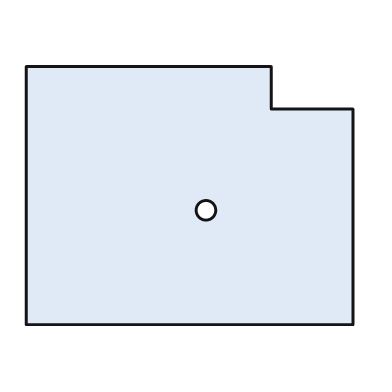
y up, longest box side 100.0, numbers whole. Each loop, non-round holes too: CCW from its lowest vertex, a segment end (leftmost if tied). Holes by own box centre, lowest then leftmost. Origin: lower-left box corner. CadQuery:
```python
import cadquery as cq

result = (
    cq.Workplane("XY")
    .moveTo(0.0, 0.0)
    .lineTo(100.0, 0.0)
    .lineTo(100.0, 66.0)
    .lineTo(75.0, 66.0)
    .lineTo(75.0, 79.0)
    .lineTo(0.0, 79.0)
    .close()
    .moveTo(55.0, 35.0)
    .circle(3.0)
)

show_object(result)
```